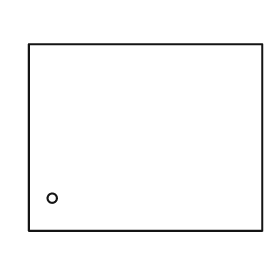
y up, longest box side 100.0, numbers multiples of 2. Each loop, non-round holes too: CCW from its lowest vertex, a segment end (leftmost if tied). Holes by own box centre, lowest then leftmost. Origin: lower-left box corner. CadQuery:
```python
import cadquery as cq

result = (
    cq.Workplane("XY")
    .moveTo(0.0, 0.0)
    .lineTo(100.0, 0.0)
    .lineTo(100.0, 80.0)
    .lineTo(0.0, 80.0)
    .close()
    .moveTo(10.0, 14.0)
    .circle(2.0)
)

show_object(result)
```